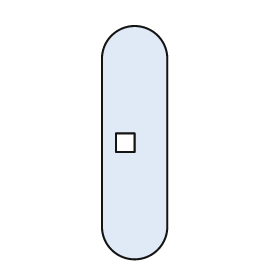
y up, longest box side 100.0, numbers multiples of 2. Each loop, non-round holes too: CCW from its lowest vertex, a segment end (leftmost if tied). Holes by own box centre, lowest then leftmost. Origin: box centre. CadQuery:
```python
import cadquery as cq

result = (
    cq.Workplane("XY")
    .moveTo(-14.0, -36.0)
    .threePointArc((0.0, -50.0), (14.0, -36.0))
    .lineTo(14.0, 36.0)
    .threePointArc((0.0, 50.0), (-14.0, 36.0))
    .close()
    .moveTo(-8.0, -4.0)
    .lineTo(0.0, -4.0)
    .lineTo(0.0, 4.0)
    .lineTo(-8.0, 4.0)
    .close()
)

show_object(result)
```